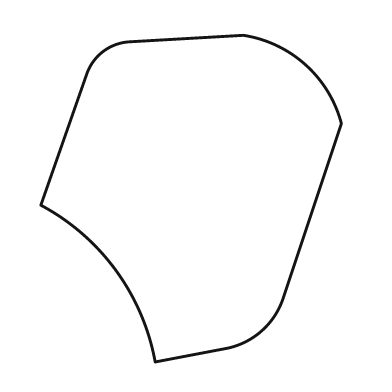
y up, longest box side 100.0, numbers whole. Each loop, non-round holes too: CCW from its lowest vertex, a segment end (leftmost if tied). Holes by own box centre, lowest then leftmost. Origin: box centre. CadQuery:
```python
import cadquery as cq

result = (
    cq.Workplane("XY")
    .moveTo(-11.0, -50.0)
    .lineTo(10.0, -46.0)
    .threePointArc((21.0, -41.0), (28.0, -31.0))
    .lineTo(46.0, 23.0)
    .threePointArc((35.0, 41.0), (16.0, 50.0))
    .lineTo(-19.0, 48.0)
    .threePointArc((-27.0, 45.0), (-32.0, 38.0))
    .lineTo(-46.0, -2.0)
    .threePointArc((-23.0, -22.0), (-11.0, -50.0))
    .close()
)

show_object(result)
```